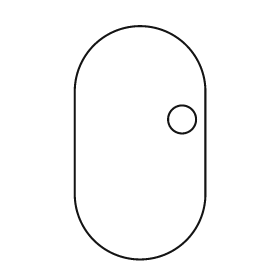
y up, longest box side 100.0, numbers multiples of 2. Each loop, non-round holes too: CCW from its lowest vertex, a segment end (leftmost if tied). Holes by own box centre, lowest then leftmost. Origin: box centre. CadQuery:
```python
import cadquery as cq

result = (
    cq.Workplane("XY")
    .moveTo(-28.0, -22.0)
    .threePointArc((0.0, -50.0), (28.0, -22.0))
    .lineTo(28.0, 22.0)
    .threePointArc((0.0, 50.0), (-28.0, 22.0))
    .close()
    .moveTo(18.0, 10.0)
    .circle(6.0)
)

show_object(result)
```